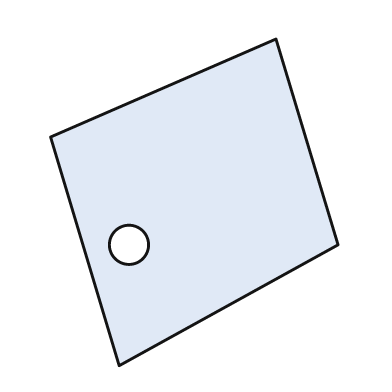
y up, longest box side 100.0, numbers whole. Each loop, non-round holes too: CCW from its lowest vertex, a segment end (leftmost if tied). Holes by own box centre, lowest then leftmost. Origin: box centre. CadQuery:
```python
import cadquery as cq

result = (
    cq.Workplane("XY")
    .moveTo(-23.0, -50.0)
    .lineTo(44.0, -13.0)
    .lineTo(25.0, 50.0)
    .lineTo(-44.0, 20.0)
    .close()
    .moveTo(-20.0, -13.0)
    .circle(6.0)
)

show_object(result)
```